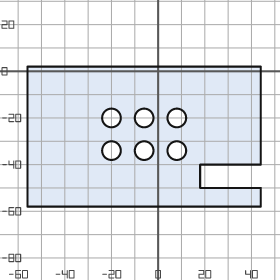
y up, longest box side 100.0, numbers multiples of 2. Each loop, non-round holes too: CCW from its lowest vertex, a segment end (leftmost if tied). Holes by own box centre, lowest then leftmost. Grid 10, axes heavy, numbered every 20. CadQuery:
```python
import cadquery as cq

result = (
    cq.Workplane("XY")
    .moveTo(-56.0, -58.0)
    .lineTo(44.0, -58.0)
    .lineTo(44.0, -50.0)
    .lineTo(18.0, -50.0)
    .lineTo(18.0, -40.0)
    .lineTo(44.0, -40.0)
    .lineTo(44.0, 2.0)
    .lineTo(-56.0, 2.0)
    .close()
    .moveTo(-20.0, -34.0)
    .circle(4.0)
    .moveTo(-6.0, -34.0)
    .circle(4.0)
    .moveTo(8.0, -34.0)
    .circle(4.0)
    .moveTo(-20.0, -20.0)
    .circle(4.0)
    .moveTo(-6.0, -20.0)
    .circle(4.0)
    .moveTo(8.0, -20.0)
    .circle(4.0)
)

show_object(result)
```